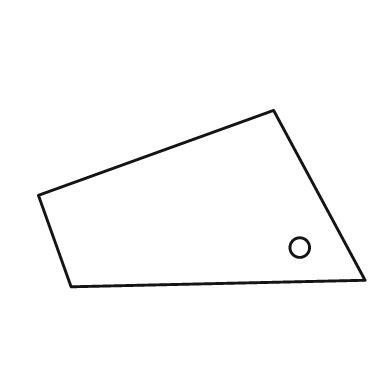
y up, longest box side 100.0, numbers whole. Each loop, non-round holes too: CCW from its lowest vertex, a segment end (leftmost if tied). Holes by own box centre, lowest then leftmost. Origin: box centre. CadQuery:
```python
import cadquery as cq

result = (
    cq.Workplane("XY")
    .moveTo(-40.0, -27.0)
    .lineTo(50.0, -25.0)
    .lineTo(22.0, 27.0)
    .lineTo(-50.0, 1.0)
    .close()
    .moveTo(30.0, -15.0)
    .circle(3.0)
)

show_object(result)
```